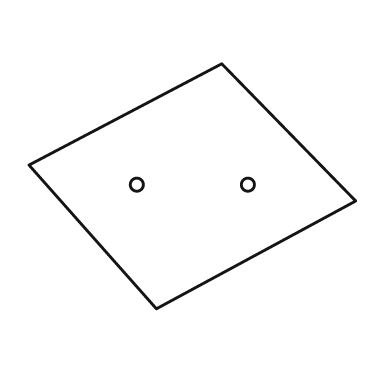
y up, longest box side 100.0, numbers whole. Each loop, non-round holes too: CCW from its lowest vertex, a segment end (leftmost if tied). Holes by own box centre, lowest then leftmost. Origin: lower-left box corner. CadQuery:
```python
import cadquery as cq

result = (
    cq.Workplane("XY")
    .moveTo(39.0, 0.0)
    .lineTo(100.0, 33.0)
    .lineTo(59.0, 75.0)
    .lineTo(0.0, 44.0)
    .close()
    .moveTo(33.0, 38.0)
    .circle(2.0)
    .moveTo(67.0, 38.0)
    .circle(2.0)
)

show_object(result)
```